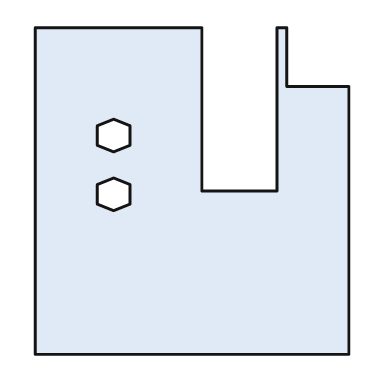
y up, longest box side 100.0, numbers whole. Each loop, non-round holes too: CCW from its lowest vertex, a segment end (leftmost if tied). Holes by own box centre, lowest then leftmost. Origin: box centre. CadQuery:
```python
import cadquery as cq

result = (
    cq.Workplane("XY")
    .moveTo(-48.0, -50.0)
    .lineTo(48.0, -50.0)
    .lineTo(48.0, 32.0)
    .lineTo(29.0, 32.0)
    .lineTo(29.0, 50.0)
    .lineTo(26.0, 50.0)
    .lineTo(26.0, 0.0)
    .lineTo(3.0, 0.0)
    .lineTo(3.0, 50.0)
    .lineTo(-48.0, 50.0)
    .close()
    .moveTo(-24.0, -6.0)
    .lineTo(-19.0, -4.0)
    .lineTo(-19.0, 2.0)
    .lineTo(-24.0, 4.0)
    .lineTo(-29.0, 2.0)
    .lineTo(-29.0, -4.0)
    .close()
    .moveTo(-24.0, 12.0)
    .lineTo(-19.0, 14.0)
    .lineTo(-19.0, 20.0)
    .lineTo(-24.0, 22.0)
    .lineTo(-29.0, 20.0)
    .lineTo(-29.0, 14.0)
    .close()
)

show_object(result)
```